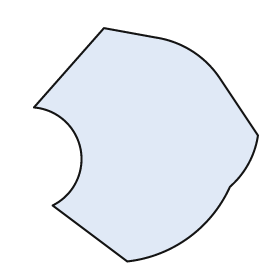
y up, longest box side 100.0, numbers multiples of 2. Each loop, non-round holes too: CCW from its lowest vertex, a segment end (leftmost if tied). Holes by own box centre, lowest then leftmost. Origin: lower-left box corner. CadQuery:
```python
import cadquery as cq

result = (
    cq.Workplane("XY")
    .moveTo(40.0, 0.0)
    .threePointArc((66.0, 10.0), (84.0, 32.0))
    .threePointArc((92.0, 42.0), (96.0, 54.0))
    .lineTo(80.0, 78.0)
    .threePointArc((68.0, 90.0), (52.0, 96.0))
    .lineTo(30.0, 100.0)
    .lineTo(0.0, 66.0)
    .threePointArc((20.0, 48.0), (8.0, 24.0))
    .close()
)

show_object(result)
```